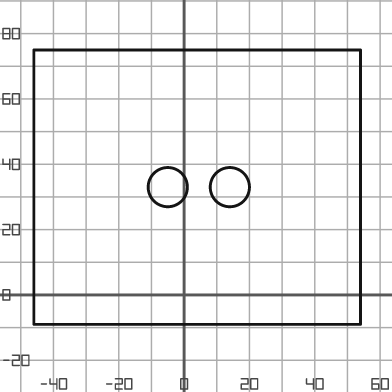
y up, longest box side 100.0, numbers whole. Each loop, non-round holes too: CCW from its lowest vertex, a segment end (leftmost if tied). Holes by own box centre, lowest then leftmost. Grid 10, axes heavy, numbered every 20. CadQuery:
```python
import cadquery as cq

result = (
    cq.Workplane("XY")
    .moveTo(-46.0, -9.0)
    .lineTo(54.0, -9.0)
    .lineTo(54.0, 75.0)
    .lineTo(-46.0, 75.0)
    .close()
    .moveTo(-5.0, 33.0)
    .circle(6.0)
    .moveTo(14.0, 33.0)
    .circle(6.0)
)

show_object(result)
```